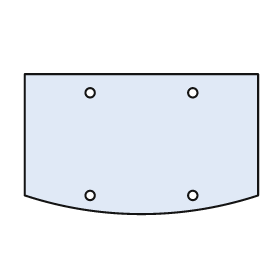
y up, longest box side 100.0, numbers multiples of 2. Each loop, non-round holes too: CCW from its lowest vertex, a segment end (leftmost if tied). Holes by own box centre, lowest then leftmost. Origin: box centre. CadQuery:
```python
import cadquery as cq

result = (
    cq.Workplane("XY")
    .moveTo(-50.0, -22.0)
    .threePointArc((0.0, -30.0), (50.0, -22.0))
    .lineTo(50.0, 30.0)
    .lineTo(-50.0, 30.0)
    .close()
    .moveTo(-22.0, -22.0)
    .circle(2.0)
    .moveTo(22.0, -22.0)
    .circle(2.0)
    .moveTo(-22.0, 22.0)
    .circle(2.0)
    .moveTo(22.0, 22.0)
    .circle(2.0)
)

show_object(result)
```